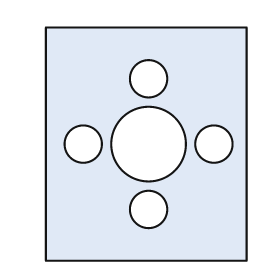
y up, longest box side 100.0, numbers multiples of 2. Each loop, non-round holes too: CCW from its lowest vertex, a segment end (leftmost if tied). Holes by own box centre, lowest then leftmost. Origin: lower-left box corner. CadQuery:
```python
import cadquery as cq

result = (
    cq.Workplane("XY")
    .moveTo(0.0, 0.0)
    .lineTo(86.0, 0.0)
    .lineTo(86.0, 100.0)
    .lineTo(0.0, 100.0)
    .close()
    .moveTo(44.0, 22.0)
    .circle(8.0)
    .moveTo(16.0, 50.0)
    .circle(8.0)
    .moveTo(44.0, 50.0)
    .circle(16.0)
    .moveTo(72.0, 50.0)
    .circle(8.0)
    .moveTo(44.0, 78.0)
    .circle(8.0)
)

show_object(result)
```